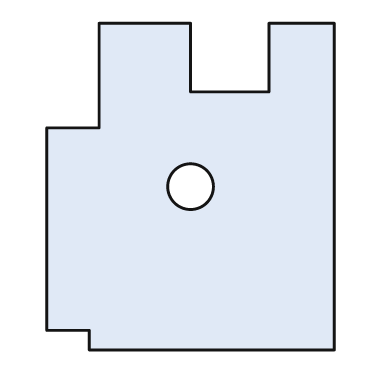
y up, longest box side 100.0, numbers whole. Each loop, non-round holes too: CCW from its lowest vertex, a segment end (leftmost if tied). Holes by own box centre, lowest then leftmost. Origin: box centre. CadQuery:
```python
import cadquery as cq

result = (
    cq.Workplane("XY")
    .moveTo(-31.0, -50.0)
    .lineTo(44.0, -50.0)
    .lineTo(44.0, 50.0)
    .lineTo(24.0, 50.0)
    .lineTo(24.0, 29.0)
    .lineTo(0.0, 29.0)
    .lineTo(0.0, 50.0)
    .lineTo(-28.0, 50.0)
    .lineTo(-28.0, 18.0)
    .lineTo(-44.0, 18.0)
    .lineTo(-44.0, -44.0)
    .lineTo(-31.0, -44.0)
    .close()
    .moveTo(0.0, 0.0)
    .circle(7.0)
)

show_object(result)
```